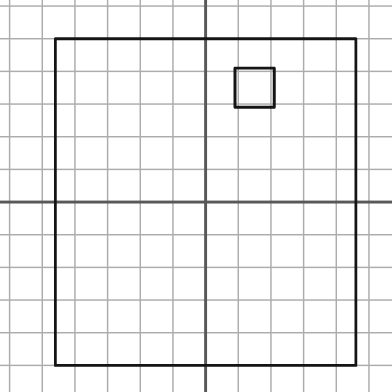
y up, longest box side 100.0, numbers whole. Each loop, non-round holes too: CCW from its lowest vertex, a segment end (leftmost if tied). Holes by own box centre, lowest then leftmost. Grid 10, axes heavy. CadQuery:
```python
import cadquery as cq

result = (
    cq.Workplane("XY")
    .moveTo(-46.0, -50.0)
    .lineTo(46.0, -50.0)
    .lineTo(46.0, 50.0)
    .lineTo(-46.0, 50.0)
    .close()
    .moveTo(9.0, 29.0)
    .lineTo(21.0, 29.0)
    .lineTo(21.0, 41.0)
    .lineTo(9.0, 41.0)
    .close()
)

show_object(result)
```